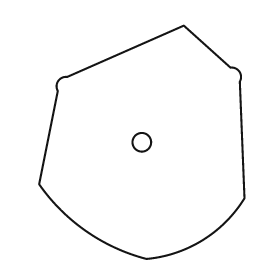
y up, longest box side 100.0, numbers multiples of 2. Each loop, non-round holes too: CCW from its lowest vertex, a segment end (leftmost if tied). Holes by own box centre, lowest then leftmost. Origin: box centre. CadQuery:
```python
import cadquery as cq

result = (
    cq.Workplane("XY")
    .moveTo(2.0, -50.0)
    .threePointArc((26.0, -42.0), (44.0, -24.0))
    .lineTo(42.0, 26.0)
    .threePointArc((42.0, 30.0), (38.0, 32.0))
    .lineTo(18.0, 50.0)
    .lineTo(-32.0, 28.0)
    .threePointArc((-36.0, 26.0), (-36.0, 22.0))
    .lineTo(-44.0, -18.0)
    .threePointArc((-24.0, -38.0), (2.0, -50.0))
    .close()
    .moveTo(0.0, 0.0)
    .circle(4.0)
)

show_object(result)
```